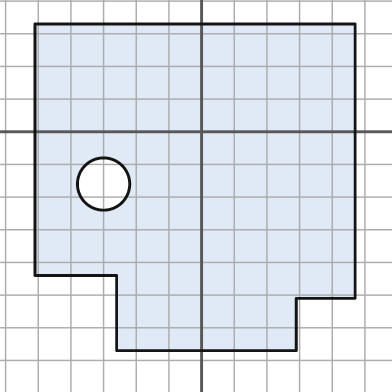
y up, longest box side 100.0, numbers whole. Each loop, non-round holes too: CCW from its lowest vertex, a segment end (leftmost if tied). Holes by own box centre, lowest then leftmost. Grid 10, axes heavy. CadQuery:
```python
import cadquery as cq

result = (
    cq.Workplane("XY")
    .moveTo(-26.0, -67.0)
    .lineTo(29.0, -67.0)
    .lineTo(29.0, -51.0)
    .lineTo(47.0, -51.0)
    .lineTo(47.0, 33.0)
    .lineTo(-51.0, 33.0)
    .lineTo(-51.0, -44.0)
    .lineTo(-26.0, -44.0)
    .close()
    .moveTo(-30.0, -16.0)
    .circle(8.0)
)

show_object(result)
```